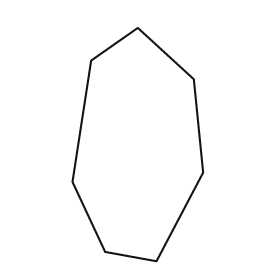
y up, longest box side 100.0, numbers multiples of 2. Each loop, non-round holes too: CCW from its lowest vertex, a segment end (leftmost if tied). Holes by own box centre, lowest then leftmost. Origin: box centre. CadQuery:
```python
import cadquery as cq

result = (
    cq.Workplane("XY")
    .moveTo(8.0, -50.0)
    .lineTo(28.0, -12.0)
    .lineTo(24.0, 28.0)
    .lineTo(0.0, 50.0)
    .lineTo(-20.0, 36.0)
    .lineTo(-28.0, -16.0)
    .lineTo(-14.0, -46.0)
    .close()
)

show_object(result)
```